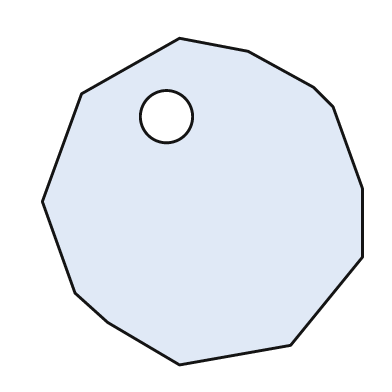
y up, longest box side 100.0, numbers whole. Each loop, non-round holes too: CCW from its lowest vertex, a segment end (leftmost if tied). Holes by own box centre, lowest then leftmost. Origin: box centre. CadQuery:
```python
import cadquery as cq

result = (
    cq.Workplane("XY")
    .moveTo(-7.0, -50.0)
    .lineTo(27.0, -44.0)
    .lineTo(49.0, -17.0)
    .lineTo(49.0, 4.0)
    .lineTo(40.0, 29.0)
    .lineTo(34.0, 35.0)
    .lineTo(14.0, 46.0)
    .lineTo(-7.0, 50.0)
    .lineTo(-37.0, 33.0)
    .lineTo(-49.0, 0.0)
    .lineTo(-39.0, -28.0)
    .lineTo(-29.0, -37.0)
    .close()
    .moveTo(-11.0, 26.0)
    .circle(8.0)
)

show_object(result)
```